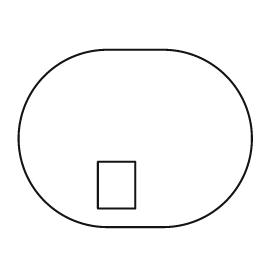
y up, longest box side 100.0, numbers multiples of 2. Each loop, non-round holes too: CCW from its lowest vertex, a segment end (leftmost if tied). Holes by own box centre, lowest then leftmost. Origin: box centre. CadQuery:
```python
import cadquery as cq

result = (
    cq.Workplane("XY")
    .moveTo(-12.0, -38.0)
    .lineTo(12.0, -38.0)
    .threePointArc((50.0, 0.0), (12.0, 38.0))
    .lineTo(-12.0, 38.0)
    .threePointArc((-50.0, 0.0), (-12.0, -38.0))
    .close()
    .moveTo(-16.0, -30.0)
    .lineTo(0.0, -30.0)
    .lineTo(0.0, -10.0)
    .lineTo(-16.0, -10.0)
    .close()
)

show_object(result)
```